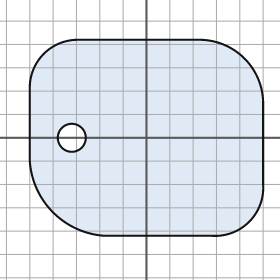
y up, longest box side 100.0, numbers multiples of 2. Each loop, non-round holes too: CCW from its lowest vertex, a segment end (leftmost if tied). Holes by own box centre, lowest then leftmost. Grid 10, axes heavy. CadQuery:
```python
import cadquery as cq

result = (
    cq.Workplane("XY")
    .moveTo(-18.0, -42.0)
    .lineTo(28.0, -42.0)
    .threePointArc((44.0, -36.0), (50.0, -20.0))
    .lineTo(50.0, 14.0)
    .threePointArc((42.0, 34.0), (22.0, 42.0))
    .lineTo(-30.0, 42.0)
    .threePointArc((-44.0, 36.0), (-50.0, 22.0))
    .lineTo(-50.0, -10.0)
    .threePointArc((-40.0, -32.0), (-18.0, -42.0))
    .close()
    .moveTo(-32.0, 0.0)
    .circle(6.0)
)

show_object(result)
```